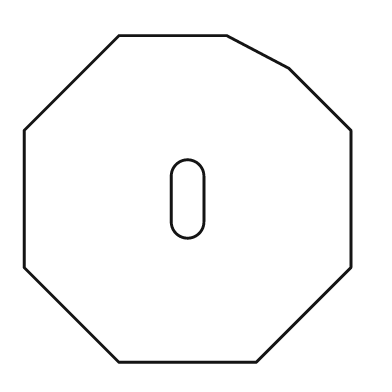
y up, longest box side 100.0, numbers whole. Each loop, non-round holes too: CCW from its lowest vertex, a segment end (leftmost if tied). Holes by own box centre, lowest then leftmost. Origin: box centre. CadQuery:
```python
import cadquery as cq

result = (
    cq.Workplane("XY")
    .moveTo(-21.0, -50.0)
    .lineTo(21.0, -50.0)
    .lineTo(50.0, -21.0)
    .lineTo(50.0, 21.0)
    .lineTo(31.0, 40.0)
    .lineTo(12.0, 50.0)
    .lineTo(-21.0, 50.0)
    .lineTo(-50.0, 21.0)
    .lineTo(-50.0, -21.0)
    .close()
    .moveTo(-5.0, -7.0)
    .threePointArc((0.0, -12.0), (5.0, -7.0))
    .lineTo(5.0, 7.0)
    .threePointArc((0.0, 12.0), (-5.0, 7.0))
    .close()
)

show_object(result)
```